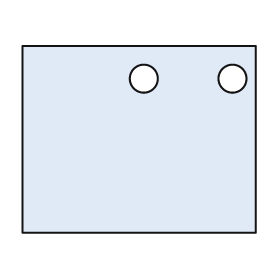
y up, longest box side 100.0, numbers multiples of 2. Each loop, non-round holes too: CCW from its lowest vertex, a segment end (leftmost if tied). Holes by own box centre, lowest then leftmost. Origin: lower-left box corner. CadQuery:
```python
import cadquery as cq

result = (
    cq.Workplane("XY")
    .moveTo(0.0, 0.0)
    .lineTo(100.0, 0.0)
    .lineTo(100.0, 80.0)
    .lineTo(0.0, 80.0)
    .close()
    .moveTo(52.0, 66.0)
    .circle(6.0)
    .moveTo(90.0, 66.0)
    .circle(6.0)
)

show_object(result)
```